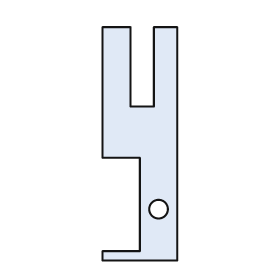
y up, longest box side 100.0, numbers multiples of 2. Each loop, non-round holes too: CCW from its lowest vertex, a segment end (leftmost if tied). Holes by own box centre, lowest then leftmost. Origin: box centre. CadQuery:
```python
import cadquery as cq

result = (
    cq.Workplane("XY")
    .moveTo(-16.0, -50.0)
    .lineTo(16.0, -50.0)
    .lineTo(16.0, 50.0)
    .lineTo(6.0, 50.0)
    .lineTo(6.0, 16.0)
    .lineTo(-4.0, 16.0)
    .lineTo(-4.0, 50.0)
    .lineTo(-16.0, 50.0)
    .lineTo(-16.0, -6.0)
    .lineTo(0.0, -6.0)
    .lineTo(0.0, -46.0)
    .lineTo(-16.0, -46.0)
    .close()
    .moveTo(8.0, -28.0)
    .circle(4.0)
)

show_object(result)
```